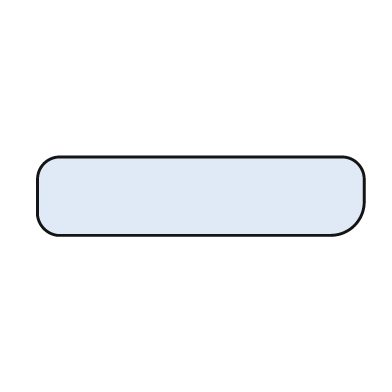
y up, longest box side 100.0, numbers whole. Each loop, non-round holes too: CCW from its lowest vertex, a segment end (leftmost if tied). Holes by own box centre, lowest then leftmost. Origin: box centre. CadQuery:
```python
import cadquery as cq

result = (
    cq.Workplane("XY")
    .moveTo(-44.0, -12.0)
    .lineTo(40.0, -12.0)
    .threePointArc((47.0, -9.0), (50.0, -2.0))
    .lineTo(50.0, 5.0)
    .threePointArc((48.0, 10.0), (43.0, 12.0))
    .lineTo(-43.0, 12.0)
    .threePointArc((-48.0, 10.0), (-50.0, 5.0))
    .lineTo(-50.0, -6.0)
    .threePointArc((-48.0, -10.0), (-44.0, -12.0))
    .close()
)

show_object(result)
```